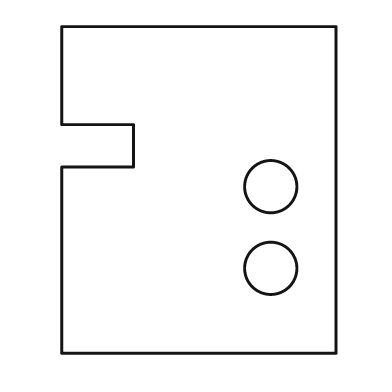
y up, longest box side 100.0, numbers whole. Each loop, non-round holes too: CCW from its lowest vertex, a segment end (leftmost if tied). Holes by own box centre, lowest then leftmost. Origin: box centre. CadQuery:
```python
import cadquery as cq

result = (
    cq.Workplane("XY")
    .moveTo(-42.0, -50.0)
    .lineTo(42.0, -50.0)
    .lineTo(42.0, 50.0)
    .lineTo(-42.0, 50.0)
    .lineTo(-42.0, 20.0)
    .lineTo(-20.0, 20.0)
    .lineTo(-20.0, 7.0)
    .lineTo(-42.0, 7.0)
    .close()
    .moveTo(22.0, -24.0)
    .circle(8.0)
    .moveTo(22.0, 1.0)
    .circle(8.0)
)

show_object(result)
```